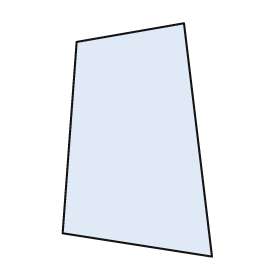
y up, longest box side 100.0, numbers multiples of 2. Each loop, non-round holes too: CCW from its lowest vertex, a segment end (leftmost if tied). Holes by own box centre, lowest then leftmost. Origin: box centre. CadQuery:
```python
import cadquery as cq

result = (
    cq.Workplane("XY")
    .moveTo(32.0, -50.0)
    .lineTo(20.0, 50.0)
    .lineTo(-26.0, 42.0)
    .lineTo(-32.0, -40.0)
    .close()
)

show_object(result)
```